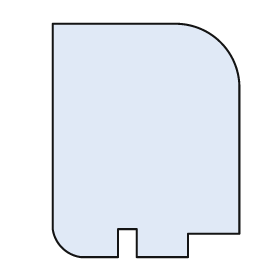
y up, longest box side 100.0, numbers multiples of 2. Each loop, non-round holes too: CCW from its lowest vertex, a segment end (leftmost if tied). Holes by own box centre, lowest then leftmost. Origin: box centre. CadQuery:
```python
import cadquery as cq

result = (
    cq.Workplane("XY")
    .moveTo(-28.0, -50.0)
    .lineTo(-12.0, -50.0)
    .lineTo(-12.0, -38.0)
    .lineTo(-4.0, -38.0)
    .lineTo(-4.0, -50.0)
    .lineTo(18.0, -50.0)
    .lineTo(18.0, -40.0)
    .lineTo(40.0, -40.0)
    .lineTo(40.0, 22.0)
    .threePointArc((32.0, 42.0), (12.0, 50.0))
    .lineTo(-40.0, 50.0)
    .lineTo(-40.0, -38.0)
    .threePointArc((-36.0, -46.0), (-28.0, -50.0))
    .close()
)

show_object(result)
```